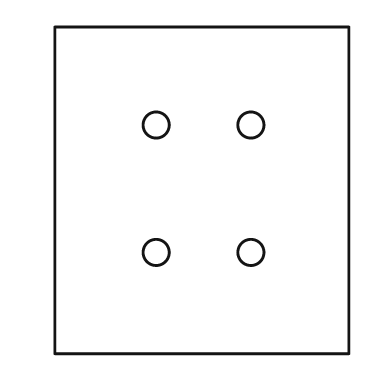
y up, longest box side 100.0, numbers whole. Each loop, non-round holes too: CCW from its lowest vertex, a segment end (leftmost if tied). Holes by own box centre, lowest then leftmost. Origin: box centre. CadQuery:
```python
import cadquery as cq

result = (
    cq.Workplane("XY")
    .moveTo(-45.0, -50.0)
    .lineTo(45.0, -50.0)
    .lineTo(45.0, 50.0)
    .lineTo(-45.0, 50.0)
    .close()
    .moveTo(-14.0, -19.0)
    .circle(4.0)
    .moveTo(15.0, -19.0)
    .circle(4.0)
    .moveTo(-14.0, 20.0)
    .circle(4.0)
    .moveTo(15.0, 20.0)
    .circle(4.0)
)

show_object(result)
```